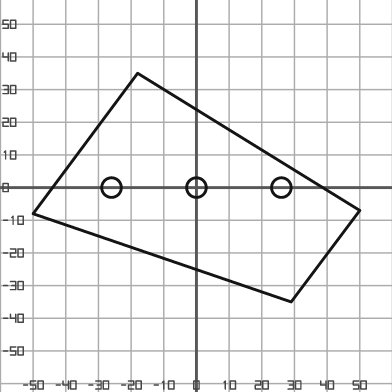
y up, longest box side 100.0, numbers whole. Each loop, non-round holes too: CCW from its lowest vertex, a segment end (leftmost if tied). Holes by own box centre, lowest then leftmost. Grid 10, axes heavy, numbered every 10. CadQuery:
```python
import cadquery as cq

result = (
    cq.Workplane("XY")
    .moveTo(29.0, -35.0)
    .lineTo(50.0, -7.0)
    .lineTo(-18.0, 35.0)
    .lineTo(-50.0, -8.0)
    .close()
    .moveTo(-26.0, 0.0)
    .circle(3.0)
    .moveTo(0.0, 0.0)
    .circle(3.0)
    .moveTo(26.0, 0.0)
    .circle(3.0)
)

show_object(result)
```